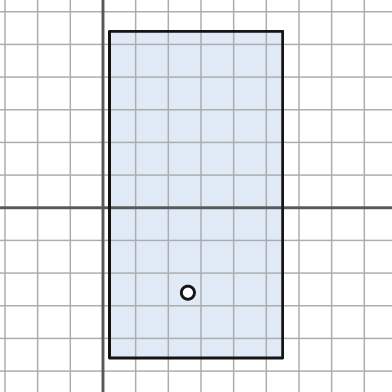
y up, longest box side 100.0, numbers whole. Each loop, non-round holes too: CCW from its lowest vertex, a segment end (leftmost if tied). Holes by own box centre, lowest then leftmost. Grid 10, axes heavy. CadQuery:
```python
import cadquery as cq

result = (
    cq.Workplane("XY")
    .moveTo(2.0, -46.0)
    .lineTo(55.0, -46.0)
    .lineTo(55.0, 54.0)
    .lineTo(2.0, 54.0)
    .close()
    .moveTo(26.0, -26.0)
    .circle(2.0)
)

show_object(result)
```